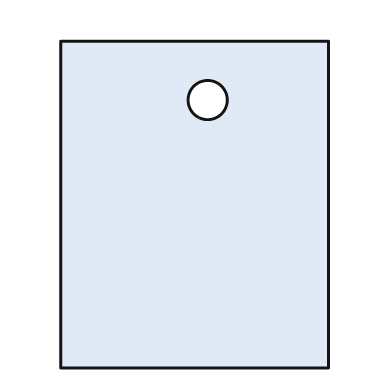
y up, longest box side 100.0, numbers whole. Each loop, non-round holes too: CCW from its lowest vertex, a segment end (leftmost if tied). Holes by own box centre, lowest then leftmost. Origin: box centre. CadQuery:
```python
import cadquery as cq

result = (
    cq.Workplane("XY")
    .moveTo(-41.0, -50.0)
    .lineTo(41.0, -50.0)
    .lineTo(41.0, 50.0)
    .lineTo(-41.0, 50.0)
    .close()
    .moveTo(4.0, 32.0)
    .circle(6.0)
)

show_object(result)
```